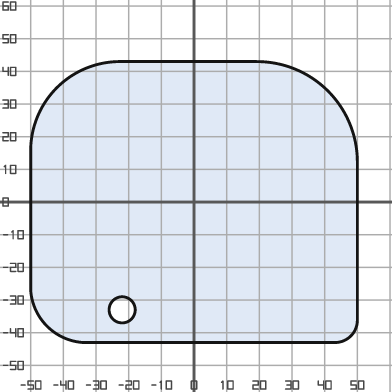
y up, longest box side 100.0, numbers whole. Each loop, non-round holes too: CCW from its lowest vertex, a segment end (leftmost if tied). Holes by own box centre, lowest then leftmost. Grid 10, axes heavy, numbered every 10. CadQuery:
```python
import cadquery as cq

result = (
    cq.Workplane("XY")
    .moveTo(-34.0, -43.0)
    .lineTo(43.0, -43.0)
    .threePointArc((48.0, -41.0), (50.0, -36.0))
    .lineTo(50.0, 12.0)
    .threePointArc((41.0, 34.0), (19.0, 43.0))
    .lineTo(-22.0, 43.0)
    .threePointArc((-42.0, 35.0), (-50.0, 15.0))
    .lineTo(-50.0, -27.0)
    .threePointArc((-45.0, -38.0), (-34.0, -43.0))
    .close()
    .moveTo(-22.0, -33.0)
    .circle(4.0)
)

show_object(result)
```